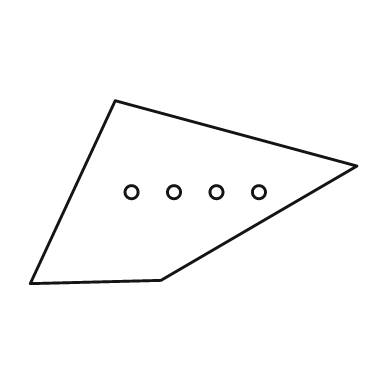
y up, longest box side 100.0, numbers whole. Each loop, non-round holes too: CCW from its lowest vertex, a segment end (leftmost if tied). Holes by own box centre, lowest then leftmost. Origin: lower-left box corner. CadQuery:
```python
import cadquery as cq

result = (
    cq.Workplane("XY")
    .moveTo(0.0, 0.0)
    .lineTo(40.0, 1.0)
    .lineTo(100.0, 36.0)
    .lineTo(26.0, 56.0)
    .close()
    .moveTo(31.0, 28.0)
    .circle(2.0)
    .moveTo(44.0, 28.0)
    .circle(2.0)
    .moveTo(57.0, 28.0)
    .circle(2.0)
    .moveTo(70.0, 28.0)
    .circle(2.0)
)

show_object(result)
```